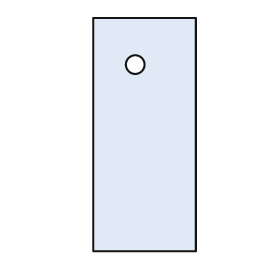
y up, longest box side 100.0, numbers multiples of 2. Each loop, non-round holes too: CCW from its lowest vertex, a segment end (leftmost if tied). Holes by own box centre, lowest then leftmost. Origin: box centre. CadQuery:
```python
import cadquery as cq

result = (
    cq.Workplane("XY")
    .moveTo(-22.0, -50.0)
    .lineTo(22.0, -50.0)
    .lineTo(22.0, 50.0)
    .lineTo(-22.0, 50.0)
    .close()
    .moveTo(-4.0, 30.0)
    .circle(4.0)
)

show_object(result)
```